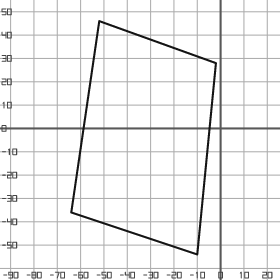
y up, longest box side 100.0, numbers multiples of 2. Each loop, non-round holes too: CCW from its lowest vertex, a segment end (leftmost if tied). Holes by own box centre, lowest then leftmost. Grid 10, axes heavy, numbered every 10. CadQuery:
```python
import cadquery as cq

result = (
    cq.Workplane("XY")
    .moveTo(-10.0, -54.0)
    .lineTo(-2.0, 28.0)
    .lineTo(-52.0, 46.0)
    .lineTo(-64.0, -36.0)
    .close()
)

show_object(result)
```